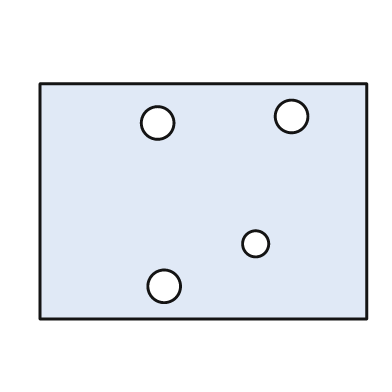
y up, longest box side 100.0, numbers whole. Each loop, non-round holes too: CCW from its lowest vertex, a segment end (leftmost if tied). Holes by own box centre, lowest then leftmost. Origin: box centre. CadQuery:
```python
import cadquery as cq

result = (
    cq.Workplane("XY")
    .moveTo(-50.0, -36.0)
    .lineTo(50.0, -36.0)
    .lineTo(50.0, 36.0)
    .lineTo(-50.0, 36.0)
    .close()
    .moveTo(-12.0, -26.0)
    .circle(5.0)
    .moveTo(16.0, -13.0)
    .circle(4.0)
    .moveTo(-14.0, 24.0)
    .circle(5.0)
    .moveTo(27.0, 26.0)
    .circle(5.0)
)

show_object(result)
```